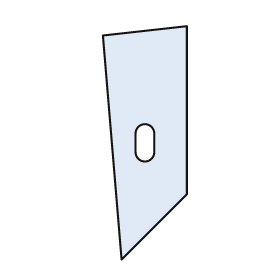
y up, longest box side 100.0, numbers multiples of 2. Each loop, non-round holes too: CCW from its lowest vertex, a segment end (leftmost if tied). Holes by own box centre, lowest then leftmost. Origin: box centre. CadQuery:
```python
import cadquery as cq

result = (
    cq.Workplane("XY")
    .moveTo(-10.0, -50.0)
    .lineTo(18.0, -22.0)
    .lineTo(18.0, 50.0)
    .lineTo(-18.0, 46.0)
    .close()
    .moveTo(-4.0, -4.0)
    .threePointArc((0.0, -8.0), (4.0, -4.0))
    .lineTo(4.0, 4.0)
    .threePointArc((0.0, 8.0), (-4.0, 4.0))
    .close()
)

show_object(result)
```